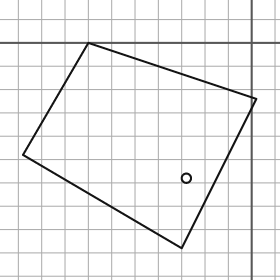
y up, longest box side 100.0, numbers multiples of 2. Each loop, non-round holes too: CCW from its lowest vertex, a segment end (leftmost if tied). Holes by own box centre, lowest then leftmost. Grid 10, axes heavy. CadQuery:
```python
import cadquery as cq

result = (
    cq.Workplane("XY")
    .moveTo(-30.0, -88.0)
    .lineTo(2.0, -24.0)
    .lineTo(-70.0, 0.0)
    .lineTo(-98.0, -48.0)
    .close()
    .moveTo(-28.0, -58.0)
    .circle(2.0)
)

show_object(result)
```